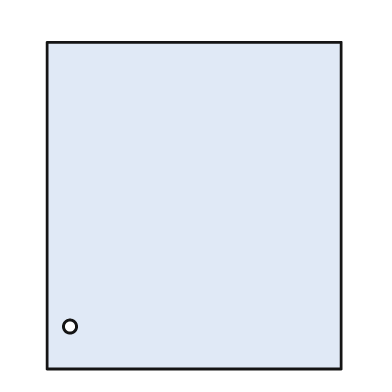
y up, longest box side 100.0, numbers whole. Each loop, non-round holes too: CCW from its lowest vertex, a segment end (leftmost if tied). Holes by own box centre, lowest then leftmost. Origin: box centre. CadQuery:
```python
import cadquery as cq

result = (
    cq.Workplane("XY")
    .moveTo(-45.0, -50.0)
    .lineTo(45.0, -50.0)
    .lineTo(45.0, 50.0)
    .lineTo(-45.0, 50.0)
    .close()
    .moveTo(-38.0, -37.0)
    .circle(2.0)
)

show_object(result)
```